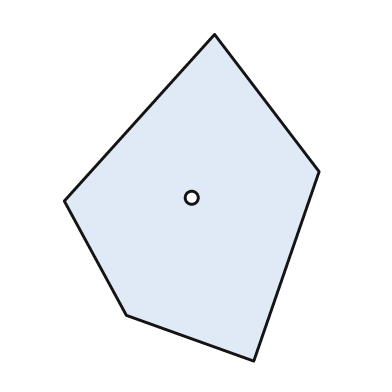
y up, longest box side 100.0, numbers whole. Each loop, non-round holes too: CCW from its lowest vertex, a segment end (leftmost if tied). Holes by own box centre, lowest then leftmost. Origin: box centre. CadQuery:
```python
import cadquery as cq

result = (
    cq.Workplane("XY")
    .moveTo(19.0, -50.0)
    .lineTo(39.0, 8.0)
    .lineTo(7.0, 50.0)
    .lineTo(-39.0, -1.0)
    .lineTo(-20.0, -36.0)
    .close()
    .moveTo(0.0, 0.0)
    .circle(2.0)
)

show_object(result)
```